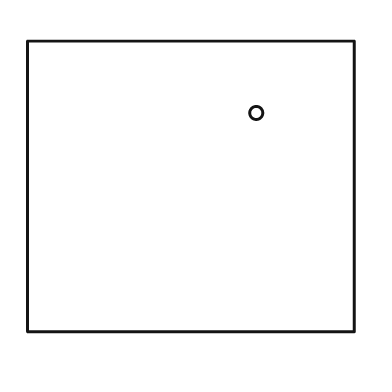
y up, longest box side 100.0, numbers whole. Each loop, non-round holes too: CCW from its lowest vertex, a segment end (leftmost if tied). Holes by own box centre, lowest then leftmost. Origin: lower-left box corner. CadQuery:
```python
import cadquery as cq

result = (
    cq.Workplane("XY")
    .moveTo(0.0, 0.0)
    .lineTo(100.0, 0.0)
    .lineTo(100.0, 89.0)
    .lineTo(0.0, 89.0)
    .close()
    .moveTo(70.0, 67.0)
    .circle(2.0)
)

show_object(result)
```